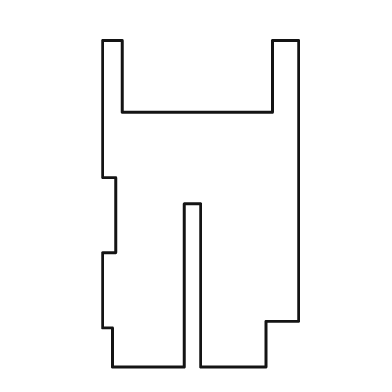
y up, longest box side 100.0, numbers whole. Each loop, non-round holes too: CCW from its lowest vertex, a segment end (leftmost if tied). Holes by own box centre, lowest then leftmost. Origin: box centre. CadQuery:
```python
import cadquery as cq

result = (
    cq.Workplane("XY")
    .moveTo(-27.0, -50.0)
    .lineTo(-5.0, -50.0)
    .lineTo(-5.0, 0.0)
    .lineTo(0.0, 0.0)
    .lineTo(0.0, -50.0)
    .lineTo(20.0, -50.0)
    .lineTo(20.0, -36.0)
    .lineTo(30.0, -36.0)
    .lineTo(30.0, 50.0)
    .lineTo(22.0, 50.0)
    .lineTo(22.0, 28.0)
    .lineTo(-24.0, 28.0)
    .lineTo(-24.0, 50.0)
    .lineTo(-30.0, 50.0)
    .lineTo(-30.0, 8.0)
    .lineTo(-26.0, 8.0)
    .lineTo(-26.0, -15.0)
    .lineTo(-30.0, -15.0)
    .lineTo(-30.0, -38.0)
    .lineTo(-27.0, -38.0)
    .close()
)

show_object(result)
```